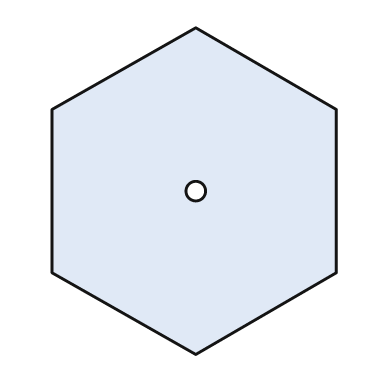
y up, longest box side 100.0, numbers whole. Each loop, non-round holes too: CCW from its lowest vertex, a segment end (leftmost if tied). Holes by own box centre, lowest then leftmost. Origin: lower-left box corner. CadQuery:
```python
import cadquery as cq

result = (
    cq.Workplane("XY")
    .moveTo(44.0, 0.0)
    .lineTo(87.0, 25.0)
    .lineTo(87.0, 75.0)
    .lineTo(44.0, 100.0)
    .lineTo(0.0, 75.0)
    .lineTo(0.0, 25.0)
    .close()
    .moveTo(44.0, 50.0)
    .circle(3.0)
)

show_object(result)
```